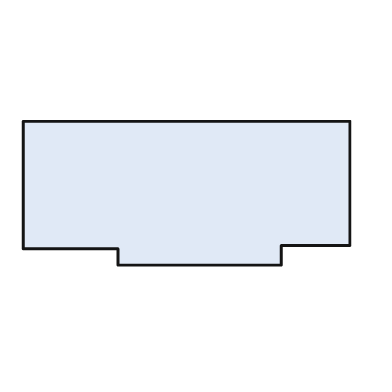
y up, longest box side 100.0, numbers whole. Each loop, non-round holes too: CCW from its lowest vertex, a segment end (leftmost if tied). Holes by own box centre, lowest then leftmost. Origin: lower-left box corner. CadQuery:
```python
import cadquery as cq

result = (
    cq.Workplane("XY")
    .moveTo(29.0, 0.0)
    .lineTo(79.0, 0.0)
    .lineTo(79.0, 6.0)
    .lineTo(100.0, 6.0)
    .lineTo(100.0, 44.0)
    .lineTo(0.0, 44.0)
    .lineTo(0.0, 5.0)
    .lineTo(29.0, 5.0)
    .close()
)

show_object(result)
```